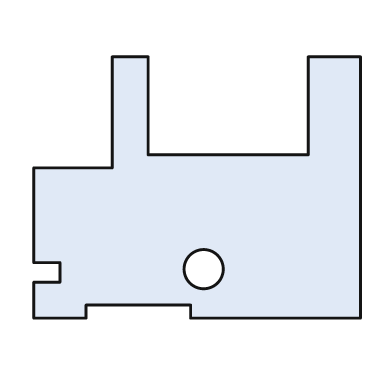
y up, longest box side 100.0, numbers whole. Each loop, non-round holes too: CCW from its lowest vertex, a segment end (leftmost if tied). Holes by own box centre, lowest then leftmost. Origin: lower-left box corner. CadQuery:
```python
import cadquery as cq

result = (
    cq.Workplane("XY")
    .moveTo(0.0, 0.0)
    .lineTo(16.0, 0.0)
    .lineTo(16.0, 4.0)
    .lineTo(48.0, 4.0)
    .lineTo(48.0, 0.0)
    .lineTo(100.0, 0.0)
    .lineTo(100.0, 80.0)
    .lineTo(84.0, 80.0)
    .lineTo(84.0, 50.0)
    .lineTo(35.0, 50.0)
    .lineTo(35.0, 80.0)
    .lineTo(24.0, 80.0)
    .lineTo(24.0, 46.0)
    .lineTo(0.0, 46.0)
    .lineTo(0.0, 17.0)
    .lineTo(8.0, 17.0)
    .lineTo(8.0, 11.0)
    .lineTo(0.0, 11.0)
    .close()
    .moveTo(52.0, 15.0)
    .circle(6.0)
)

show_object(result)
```